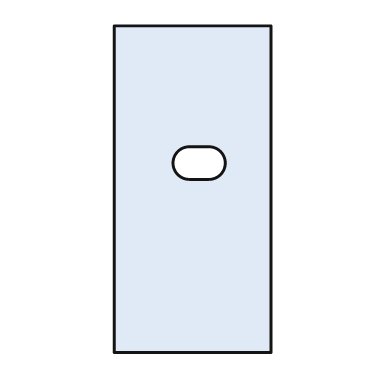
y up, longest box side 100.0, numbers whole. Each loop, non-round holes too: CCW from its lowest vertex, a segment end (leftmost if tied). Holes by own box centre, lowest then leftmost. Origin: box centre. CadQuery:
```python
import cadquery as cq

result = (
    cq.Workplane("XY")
    .moveTo(-24.0, -50.0)
    .lineTo(24.0, -50.0)
    .lineTo(24.0, 50.0)
    .lineTo(-24.0, 50.0)
    .close()
    .moveTo(-1.0, 3.0)
    .lineTo(5.0, 3.0)
    .threePointArc((10.0, 8.0), (5.0, 13.0))
    .lineTo(-1.0, 13.0)
    .threePointArc((-6.0, 8.0), (-1.0, 3.0))
    .close()
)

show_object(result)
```